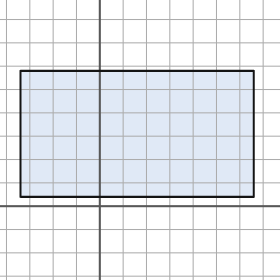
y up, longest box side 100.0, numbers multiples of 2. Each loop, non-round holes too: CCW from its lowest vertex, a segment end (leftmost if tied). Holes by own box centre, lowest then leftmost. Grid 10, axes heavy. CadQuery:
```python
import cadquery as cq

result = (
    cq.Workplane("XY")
    .moveTo(-34.0, 4.0)
    .lineTo(66.0, 4.0)
    .lineTo(66.0, 58.0)
    .lineTo(-34.0, 58.0)
    .close()
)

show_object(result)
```